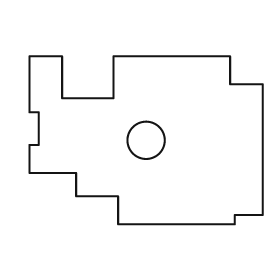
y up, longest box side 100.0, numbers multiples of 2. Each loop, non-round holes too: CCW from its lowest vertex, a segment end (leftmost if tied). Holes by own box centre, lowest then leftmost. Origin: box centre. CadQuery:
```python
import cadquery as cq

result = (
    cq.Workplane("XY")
    .moveTo(-12.0, -36.0)
    .lineTo(38.0, -36.0)
    .lineTo(38.0, -32.0)
    .lineTo(50.0, -32.0)
    .lineTo(50.0, 24.0)
    .lineTo(36.0, 24.0)
    .lineTo(36.0, 36.0)
    .lineTo(-14.0, 36.0)
    .lineTo(-14.0, 18.0)
    .lineTo(-36.0, 18.0)
    .lineTo(-36.0, 36.0)
    .lineTo(-50.0, 36.0)
    .lineTo(-50.0, 12.0)
    .lineTo(-46.0, 12.0)
    .lineTo(-46.0, -2.0)
    .lineTo(-50.0, -2.0)
    .lineTo(-50.0, -14.0)
    .lineTo(-30.0, -14.0)
    .lineTo(-30.0, -24.0)
    .lineTo(-12.0, -24.0)
    .close()
    .moveTo(0.0, 0.0)
    .circle(8.0)
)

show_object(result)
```